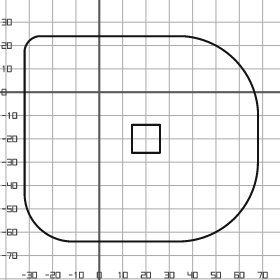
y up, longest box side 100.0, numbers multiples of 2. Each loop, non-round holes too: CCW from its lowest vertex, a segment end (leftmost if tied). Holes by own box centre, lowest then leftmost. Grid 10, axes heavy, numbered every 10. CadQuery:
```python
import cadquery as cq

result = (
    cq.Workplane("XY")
    .moveTo(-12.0, -64.0)
    .lineTo(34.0, -64.0)
    .threePointArc((58.0, -54.0), (68.0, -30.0))
    .lineTo(68.0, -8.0)
    .threePointArc((58.0, 14.0), (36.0, 24.0))
    .lineTo(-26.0, 24.0)
    .threePointArc((-30.0, 22.0), (-32.0, 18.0))
    .lineTo(-32.0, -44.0)
    .threePointArc((-26.0, -58.0), (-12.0, -64.0))
    .close()
    .moveTo(14.0, -26.0)
    .lineTo(26.0, -26.0)
    .lineTo(26.0, -14.0)
    .lineTo(14.0, -14.0)
    .close()
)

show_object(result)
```